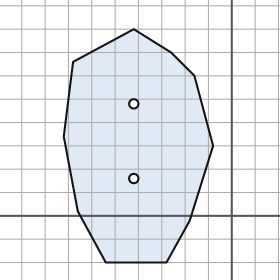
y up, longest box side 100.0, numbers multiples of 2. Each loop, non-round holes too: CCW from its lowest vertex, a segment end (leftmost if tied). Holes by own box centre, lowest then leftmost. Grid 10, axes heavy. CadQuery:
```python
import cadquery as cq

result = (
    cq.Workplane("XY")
    .moveTo(-54.0, -20.0)
    .lineTo(-28.0, -20.0)
    .lineTo(-18.0, -2.0)
    .lineTo(-8.0, 30.0)
    .lineTo(-16.0, 60.0)
    .lineTo(-26.0, 70.0)
    .lineTo(-42.0, 80.0)
    .lineTo(-68.0, 66.0)
    .lineTo(-72.0, 34.0)
    .lineTo(-66.0, 2.0)
    .close()
    .moveTo(-42.0, 16.0)
    .circle(2.0)
    .moveTo(-42.0, 48.0)
    .circle(2.0)
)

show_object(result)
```